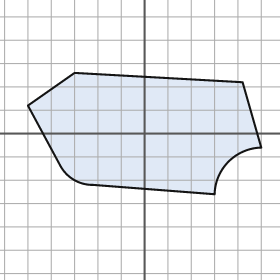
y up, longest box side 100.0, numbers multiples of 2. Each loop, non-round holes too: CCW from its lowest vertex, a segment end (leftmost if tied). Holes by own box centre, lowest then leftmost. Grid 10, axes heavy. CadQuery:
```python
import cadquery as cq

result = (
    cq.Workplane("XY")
    .moveTo(30.0, -26.0)
    .threePointArc((36.0, -12.0), (50.0, -6.0))
    .lineTo(42.0, 22.0)
    .lineTo(-30.0, 26.0)
    .lineTo(-50.0, 12.0)
    .lineTo(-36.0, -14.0)
    .threePointArc((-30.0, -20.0), (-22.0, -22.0))
    .close()
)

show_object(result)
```